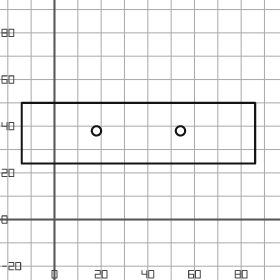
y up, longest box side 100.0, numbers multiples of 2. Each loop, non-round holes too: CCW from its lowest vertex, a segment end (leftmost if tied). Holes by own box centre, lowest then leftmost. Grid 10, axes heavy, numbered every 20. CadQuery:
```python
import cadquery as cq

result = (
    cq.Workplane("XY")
    .moveTo(-14.0, 24.0)
    .lineTo(86.0, 24.0)
    .lineTo(86.0, 50.0)
    .lineTo(-14.0, 50.0)
    .close()
    .moveTo(18.0, 38.0)
    .circle(2.0)
    .moveTo(54.0, 38.0)
    .circle(2.0)
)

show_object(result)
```